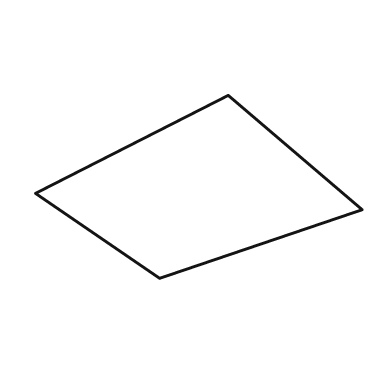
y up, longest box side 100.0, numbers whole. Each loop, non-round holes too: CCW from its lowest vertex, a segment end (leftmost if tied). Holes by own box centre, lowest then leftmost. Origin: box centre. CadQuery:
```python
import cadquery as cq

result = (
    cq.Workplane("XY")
    .moveTo(-12.0, -28.0)
    .lineTo(50.0, -7.0)
    .lineTo(9.0, 28.0)
    .lineTo(-50.0, -2.0)
    .close()
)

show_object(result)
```